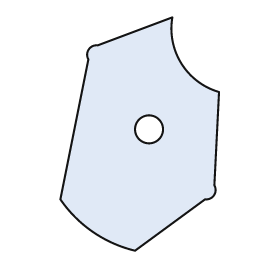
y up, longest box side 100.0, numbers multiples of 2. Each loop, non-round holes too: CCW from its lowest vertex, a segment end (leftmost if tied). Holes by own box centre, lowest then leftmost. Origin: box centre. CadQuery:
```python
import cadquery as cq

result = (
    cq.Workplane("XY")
    .moveTo(-2.0, -50.0)
    .lineTo(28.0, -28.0)
    .threePointArc((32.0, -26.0), (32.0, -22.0))
    .lineTo(34.0, 18.0)
    .threePointArc((18.0, 30.0), (14.0, 50.0))
    .lineTo(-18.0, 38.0)
    .threePointArc((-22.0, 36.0), (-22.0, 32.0))
    .lineTo(-34.0, -28.0)
    .threePointArc((-20.0, -42.0), (-2.0, -50.0))
    .close()
    .moveTo(4.0, 2.0)
    .circle(6.0)
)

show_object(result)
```